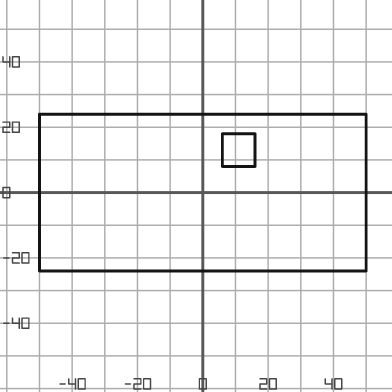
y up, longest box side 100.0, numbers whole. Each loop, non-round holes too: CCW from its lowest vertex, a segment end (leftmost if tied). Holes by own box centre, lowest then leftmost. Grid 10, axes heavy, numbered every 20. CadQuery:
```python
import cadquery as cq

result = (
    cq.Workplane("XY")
    .moveTo(-50.0, -24.0)
    .lineTo(50.0, -24.0)
    .lineTo(50.0, 24.0)
    .lineTo(-50.0, 24.0)
    .close()
    .moveTo(6.0, 8.0)
    .lineTo(16.0, 8.0)
    .lineTo(16.0, 18.0)
    .lineTo(6.0, 18.0)
    .close()
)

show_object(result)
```